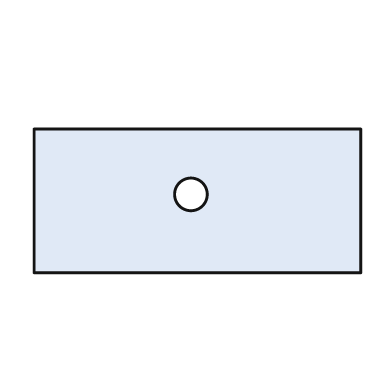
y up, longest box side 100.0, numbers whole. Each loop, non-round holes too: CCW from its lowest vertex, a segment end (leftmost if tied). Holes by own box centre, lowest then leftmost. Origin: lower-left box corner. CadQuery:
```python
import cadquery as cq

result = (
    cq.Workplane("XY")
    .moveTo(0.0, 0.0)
    .lineTo(100.0, 0.0)
    .lineTo(100.0, 44.0)
    .lineTo(0.0, 44.0)
    .close()
    .moveTo(48.0, 24.0)
    .circle(5.0)
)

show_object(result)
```